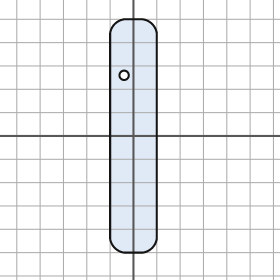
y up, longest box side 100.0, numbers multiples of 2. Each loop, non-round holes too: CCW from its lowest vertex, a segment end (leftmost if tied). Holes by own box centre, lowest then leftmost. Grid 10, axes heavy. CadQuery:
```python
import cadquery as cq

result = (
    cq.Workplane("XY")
    .moveTo(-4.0, -50.0)
    .lineTo(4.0, -50.0)
    .threePointArc((8.0, -48.0), (10.0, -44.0))
    .lineTo(10.0, 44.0)
    .threePointArc((8.0, 48.0), (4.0, 50.0))
    .lineTo(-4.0, 50.0)
    .threePointArc((-8.0, 48.0), (-10.0, 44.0))
    .lineTo(-10.0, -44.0)
    .threePointArc((-8.0, -48.0), (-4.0, -50.0))
    .close()
    .moveTo(-4.0, 26.0)
    .circle(2.0)
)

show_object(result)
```